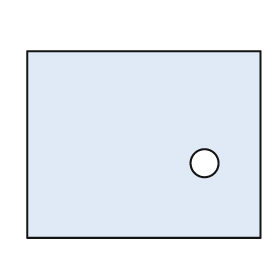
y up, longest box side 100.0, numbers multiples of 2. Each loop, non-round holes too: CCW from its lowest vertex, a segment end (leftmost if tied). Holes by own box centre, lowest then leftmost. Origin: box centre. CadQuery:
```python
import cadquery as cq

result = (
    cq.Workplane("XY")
    .moveTo(-50.0, -40.0)
    .lineTo(50.0, -40.0)
    .lineTo(50.0, 40.0)
    .lineTo(-50.0, 40.0)
    .close()
    .moveTo(26.0, -8.0)
    .circle(6.0)
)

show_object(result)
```